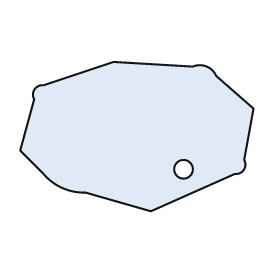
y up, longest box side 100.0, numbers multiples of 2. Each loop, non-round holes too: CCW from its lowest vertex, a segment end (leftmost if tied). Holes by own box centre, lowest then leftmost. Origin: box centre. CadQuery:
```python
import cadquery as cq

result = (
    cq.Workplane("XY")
    .moveTo(6.0, -32.0)
    .lineTo(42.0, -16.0)
    .threePointArc((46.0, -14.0), (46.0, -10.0))
    .lineTo(50.0, 12.0)
    .lineTo(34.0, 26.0)
    .threePointArc((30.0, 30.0), (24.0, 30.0))
    .lineTo(-10.0, 32.0)
    .lineTo(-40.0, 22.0)
    .threePointArc((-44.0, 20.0), (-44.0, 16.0))
    .lineTo(-50.0, -6.0)
    .lineTo(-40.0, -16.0)
    .threePointArc((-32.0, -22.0), (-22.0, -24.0))
    .close()
    .moveTo(20.0, -14.0)
    .circle(4.0)
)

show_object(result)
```